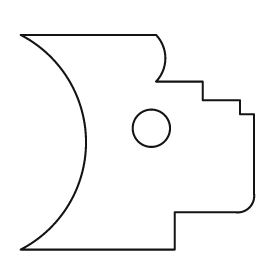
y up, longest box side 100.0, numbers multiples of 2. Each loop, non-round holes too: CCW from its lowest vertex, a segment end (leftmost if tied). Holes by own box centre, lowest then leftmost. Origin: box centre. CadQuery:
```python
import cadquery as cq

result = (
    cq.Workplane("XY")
    .moveTo(-50.0, -46.0)
    .lineTo(16.0, -46.0)
    .lineTo(16.0, -30.0)
    .lineTo(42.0, -30.0)
    .threePointArc((48.0, -28.0), (50.0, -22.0))
    .lineTo(50.0, 12.0)
    .lineTo(44.0, 12.0)
    .lineTo(44.0, 18.0)
    .lineTo(28.0, 18.0)
    .lineTo(28.0, 26.0)
    .lineTo(8.0, 26.0)
    .threePointArc((12.0, 36.0), (8.0, 46.0))
    .lineTo(-50.0, 46.0)
    .threePointArc((-22.0, 0.0), (-50.0, -46.0))
    .close()
    .moveTo(6.0, 6.0)
    .circle(8.0)
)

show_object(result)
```